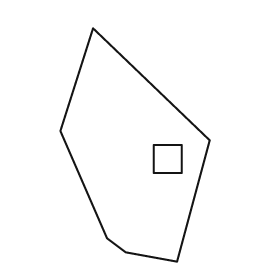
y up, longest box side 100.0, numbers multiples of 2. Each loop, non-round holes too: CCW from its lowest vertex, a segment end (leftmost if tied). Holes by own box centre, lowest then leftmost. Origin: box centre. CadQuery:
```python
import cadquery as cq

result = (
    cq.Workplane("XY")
    .moveTo(18.0, -50.0)
    .lineTo(32.0, 2.0)
    .lineTo(-18.0, 50.0)
    .lineTo(-32.0, 6.0)
    .lineTo(-12.0, -40.0)
    .lineTo(-4.0, -46.0)
    .close()
    .moveTo(8.0, -12.0)
    .lineTo(20.0, -12.0)
    .lineTo(20.0, 0.0)
    .lineTo(8.0, 0.0)
    .close()
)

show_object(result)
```